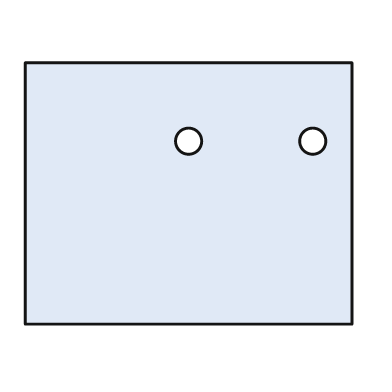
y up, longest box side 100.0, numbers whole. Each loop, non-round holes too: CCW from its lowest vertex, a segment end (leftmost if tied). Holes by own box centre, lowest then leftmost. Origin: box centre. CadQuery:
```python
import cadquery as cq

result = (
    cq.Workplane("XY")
    .moveTo(-50.0, -40.0)
    .lineTo(50.0, -40.0)
    .lineTo(50.0, 40.0)
    .lineTo(-50.0, 40.0)
    .close()
    .moveTo(0.0, 16.0)
    .circle(4.0)
    .moveTo(38.0, 16.0)
    .circle(4.0)
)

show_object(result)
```